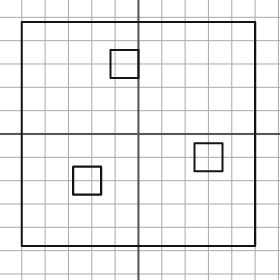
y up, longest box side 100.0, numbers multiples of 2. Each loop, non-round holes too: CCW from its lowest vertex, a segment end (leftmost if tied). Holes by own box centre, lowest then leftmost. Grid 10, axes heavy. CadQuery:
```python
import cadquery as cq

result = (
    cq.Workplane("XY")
    .moveTo(-50.0, -48.0)
    .lineTo(50.0, -48.0)
    .lineTo(50.0, 48.0)
    .lineTo(-50.0, 48.0)
    .close()
    .moveTo(-28.0, -26.0)
    .lineTo(-16.0, -26.0)
    .lineTo(-16.0, -14.0)
    .lineTo(-28.0, -14.0)
    .close()
    .moveTo(24.0, -16.0)
    .lineTo(36.0, -16.0)
    .lineTo(36.0, -4.0)
    .lineTo(24.0, -4.0)
    .close()
    .moveTo(-12.0, 24.0)
    .lineTo(0.0, 24.0)
    .lineTo(0.0, 36.0)
    .lineTo(-12.0, 36.0)
    .close()
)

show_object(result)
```